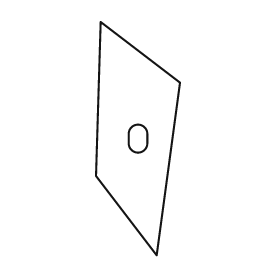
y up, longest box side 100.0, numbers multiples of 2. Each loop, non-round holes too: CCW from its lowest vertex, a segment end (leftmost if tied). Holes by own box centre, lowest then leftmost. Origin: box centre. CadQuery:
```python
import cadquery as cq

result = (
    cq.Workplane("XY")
    .moveTo(8.0, -50.0)
    .lineTo(18.0, 24.0)
    .lineTo(-16.0, 50.0)
    .lineTo(-18.0, -16.0)
    .close()
    .moveTo(-4.0, -2.0)
    .threePointArc((0.0, -6.0), (4.0, -2.0))
    .lineTo(4.0, 2.0)
    .threePointArc((0.0, 6.0), (-4.0, 2.0))
    .close()
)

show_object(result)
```